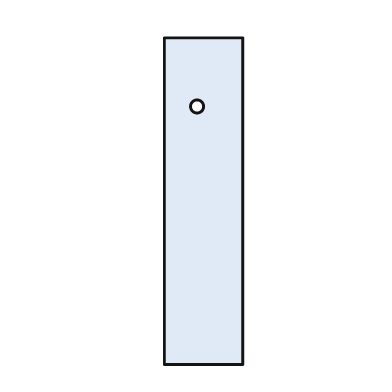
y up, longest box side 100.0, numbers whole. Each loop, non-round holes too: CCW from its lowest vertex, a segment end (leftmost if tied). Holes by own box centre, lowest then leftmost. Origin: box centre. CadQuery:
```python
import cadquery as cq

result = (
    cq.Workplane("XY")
    .moveTo(-12.0, -50.0)
    .lineTo(12.0, -50.0)
    .lineTo(12.0, 50.0)
    .lineTo(-12.0, 50.0)
    .close()
    .moveTo(-2.0, 29.0)
    .circle(2.0)
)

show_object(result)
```